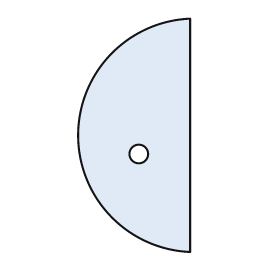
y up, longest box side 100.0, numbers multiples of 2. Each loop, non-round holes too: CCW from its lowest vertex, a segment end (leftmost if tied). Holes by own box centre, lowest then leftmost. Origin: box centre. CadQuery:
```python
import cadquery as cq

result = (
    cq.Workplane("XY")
    .moveTo(24.0, -50.0)
    .lineTo(24.0, 50.0)
    .threePointArc((-24.0, 0.0), (24.0, -50.0))
    .close()
    .moveTo(2.0, -8.0)
    .circle(4.0)
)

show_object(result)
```